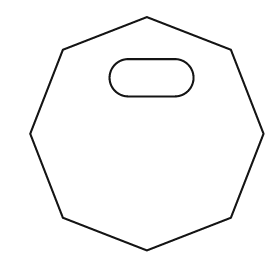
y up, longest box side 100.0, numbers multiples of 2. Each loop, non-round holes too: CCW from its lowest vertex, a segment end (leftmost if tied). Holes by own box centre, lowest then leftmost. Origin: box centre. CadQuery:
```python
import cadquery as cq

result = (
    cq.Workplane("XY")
    .moveTo(0.0, -50.0)
    .lineTo(36.0, -36.0)
    .lineTo(50.0, 0.0)
    .lineTo(36.0, 36.0)
    .lineTo(0.0, 50.0)
    .lineTo(-36.0, 36.0)
    .lineTo(-50.0, 0.0)
    .lineTo(-36.0, -36.0)
    .close()
    .moveTo(-8.0, 16.0)
    .lineTo(12.0, 16.0)
    .threePointArc((20.0, 24.0), (12.0, 32.0))
    .lineTo(-8.0, 32.0)
    .threePointArc((-16.0, 24.0), (-8.0, 16.0))
    .close()
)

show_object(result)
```